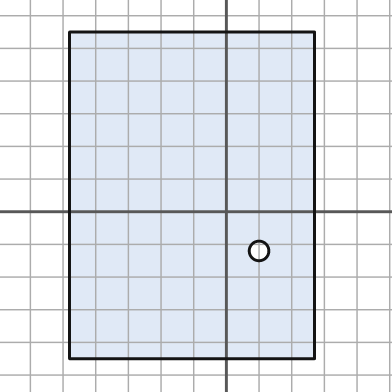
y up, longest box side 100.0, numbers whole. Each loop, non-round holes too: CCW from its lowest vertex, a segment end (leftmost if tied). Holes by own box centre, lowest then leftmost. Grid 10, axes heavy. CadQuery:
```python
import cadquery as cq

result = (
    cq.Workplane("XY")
    .moveTo(-48.0, -45.0)
    .lineTo(27.0, -45.0)
    .lineTo(27.0, 55.0)
    .lineTo(-48.0, 55.0)
    .close()
    .moveTo(10.0, -12.0)
    .circle(3.0)
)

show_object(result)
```